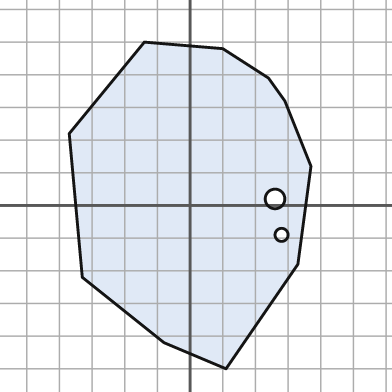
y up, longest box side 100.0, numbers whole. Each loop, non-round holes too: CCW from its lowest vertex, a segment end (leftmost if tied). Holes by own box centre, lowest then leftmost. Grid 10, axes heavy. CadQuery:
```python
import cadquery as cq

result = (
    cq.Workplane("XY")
    .moveTo(11.0, -50.0)
    .lineTo(33.0, -18.0)
    .lineTo(37.0, 12.0)
    .lineTo(29.0, 32.0)
    .lineTo(24.0, 39.0)
    .lineTo(10.0, 48.0)
    .lineTo(-14.0, 50.0)
    .lineTo(-37.0, 22.0)
    .lineTo(-33.0, -22.0)
    .lineTo(-8.0, -42.0)
    .close()
    .moveTo(28.0, -9.0)
    .circle(2.0)
    .moveTo(26.0, 2.0)
    .circle(3.0)
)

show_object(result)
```